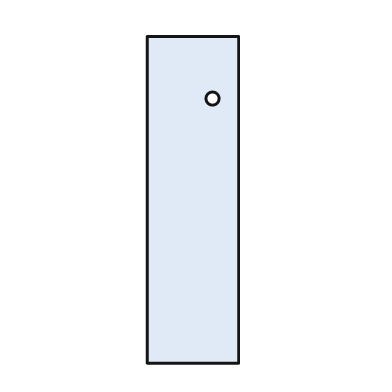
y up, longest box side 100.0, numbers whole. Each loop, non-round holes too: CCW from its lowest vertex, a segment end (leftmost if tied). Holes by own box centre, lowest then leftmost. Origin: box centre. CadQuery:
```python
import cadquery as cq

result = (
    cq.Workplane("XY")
    .moveTo(-14.0, -50.0)
    .lineTo(14.0, -50.0)
    .lineTo(14.0, 50.0)
    .lineTo(-14.0, 50.0)
    .close()
    .moveTo(6.0, 31.0)
    .circle(2.0)
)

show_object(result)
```